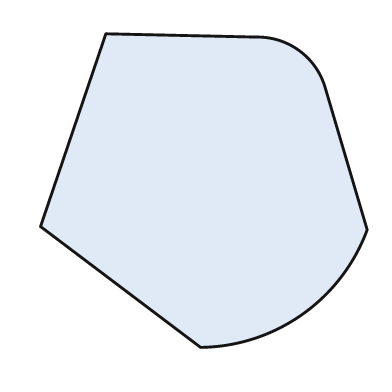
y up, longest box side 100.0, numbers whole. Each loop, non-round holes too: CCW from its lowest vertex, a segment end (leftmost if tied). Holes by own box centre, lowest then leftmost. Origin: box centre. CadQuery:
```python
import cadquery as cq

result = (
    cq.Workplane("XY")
    .moveTo(-1.0, -48.0)
    .threePointArc((30.0, -38.0), (50.0, -12.0))
    .lineTo(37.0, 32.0)
    .threePointArc((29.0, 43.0), (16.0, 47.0))
    .lineTo(-30.0, 48.0)
    .lineTo(-50.0, -11.0)
    .close()
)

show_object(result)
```